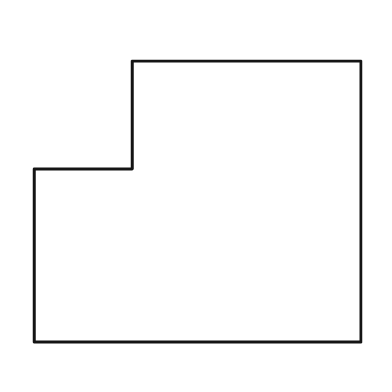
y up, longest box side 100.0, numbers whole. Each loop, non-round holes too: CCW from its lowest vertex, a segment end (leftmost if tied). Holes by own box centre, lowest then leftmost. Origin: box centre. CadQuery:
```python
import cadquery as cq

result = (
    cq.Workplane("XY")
    .moveTo(-50.0, -43.0)
    .lineTo(50.0, -43.0)
    .lineTo(50.0, 43.0)
    .lineTo(-20.0, 43.0)
    .lineTo(-20.0, 10.0)
    .lineTo(-50.0, 10.0)
    .close()
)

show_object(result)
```